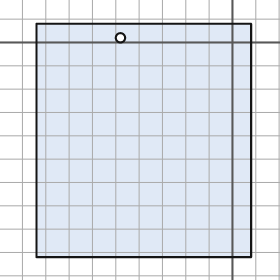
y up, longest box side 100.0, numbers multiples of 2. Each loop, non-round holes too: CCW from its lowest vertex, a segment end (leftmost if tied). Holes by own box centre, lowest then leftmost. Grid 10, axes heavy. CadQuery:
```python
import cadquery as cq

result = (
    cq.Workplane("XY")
    .moveTo(-84.0, -92.0)
    .lineTo(8.0, -92.0)
    .lineTo(8.0, 8.0)
    .lineTo(-84.0, 8.0)
    .close()
    .moveTo(-48.0, 2.0)
    .circle(2.0)
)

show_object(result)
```